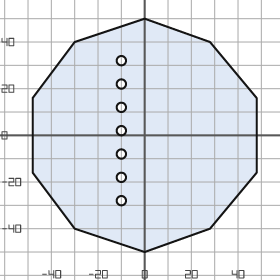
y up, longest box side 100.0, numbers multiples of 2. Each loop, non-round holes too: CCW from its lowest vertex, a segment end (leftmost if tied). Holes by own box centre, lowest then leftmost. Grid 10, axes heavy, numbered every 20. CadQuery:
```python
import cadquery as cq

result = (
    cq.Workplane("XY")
    .moveTo(0.0, -50.0)
    .lineTo(28.0, -40.0)
    .lineTo(48.0, -16.0)
    .lineTo(48.0, 16.0)
    .lineTo(28.0, 40.0)
    .lineTo(0.0, 50.0)
    .lineTo(-30.0, 40.0)
    .lineTo(-48.0, 16.0)
    .lineTo(-48.0, -16.0)
    .lineTo(-30.0, -40.0)
    .close()
    .moveTo(-10.0, -28.0)
    .circle(2.0)
    .moveTo(-10.0, -18.0)
    .circle(2.0)
    .moveTo(-10.0, -8.0)
    .circle(2.0)
    .moveTo(-10.0, 2.0)
    .circle(2.0)
    .moveTo(-10.0, 12.0)
    .circle(2.0)
    .moveTo(-10.0, 22.0)
    .circle(2.0)
    .moveTo(-10.0, 32.0)
    .circle(2.0)
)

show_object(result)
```